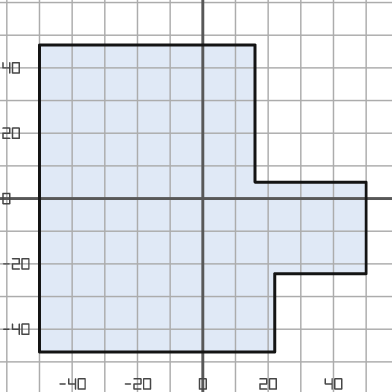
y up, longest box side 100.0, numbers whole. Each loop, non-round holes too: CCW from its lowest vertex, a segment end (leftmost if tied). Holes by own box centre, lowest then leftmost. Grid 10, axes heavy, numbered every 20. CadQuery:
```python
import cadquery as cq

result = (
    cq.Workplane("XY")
    .moveTo(-50.0, -47.0)
    .lineTo(22.0, -47.0)
    .lineTo(22.0, -23.0)
    .lineTo(50.0, -23.0)
    .lineTo(50.0, 5.0)
    .lineTo(16.0, 5.0)
    .lineTo(16.0, 47.0)
    .lineTo(-50.0, 47.0)
    .close()
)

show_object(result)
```